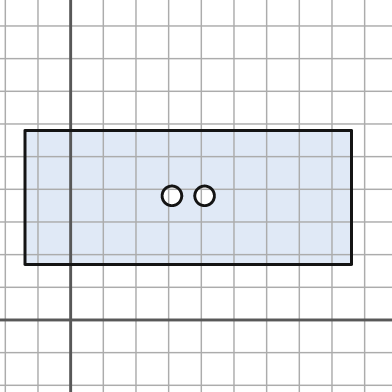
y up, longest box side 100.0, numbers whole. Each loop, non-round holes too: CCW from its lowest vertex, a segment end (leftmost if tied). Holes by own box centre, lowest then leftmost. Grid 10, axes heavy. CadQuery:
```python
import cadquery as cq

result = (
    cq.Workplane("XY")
    .moveTo(-14.0, 17.0)
    .lineTo(86.0, 17.0)
    .lineTo(86.0, 58.0)
    .lineTo(-14.0, 58.0)
    .close()
    .moveTo(31.0, 38.0)
    .circle(3.0)
    .moveTo(41.0, 38.0)
    .circle(3.0)
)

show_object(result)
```